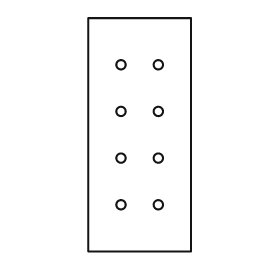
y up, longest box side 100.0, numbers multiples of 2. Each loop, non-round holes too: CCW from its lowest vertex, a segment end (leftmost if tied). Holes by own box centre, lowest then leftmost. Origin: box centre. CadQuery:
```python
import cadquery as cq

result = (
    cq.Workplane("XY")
    .moveTo(-22.0, -50.0)
    .lineTo(22.0, -50.0)
    .lineTo(22.0, 50.0)
    .lineTo(-22.0, 50.0)
    .close()
    .moveTo(-8.0, -30.0)
    .circle(2.0)
    .moveTo(8.0, -30.0)
    .circle(2.0)
    .moveTo(-8.0, -10.0)
    .circle(2.0)
    .moveTo(8.0, -10.0)
    .circle(2.0)
    .moveTo(-8.0, 10.0)
    .circle(2.0)
    .moveTo(8.0, 10.0)
    .circle(2.0)
    .moveTo(-8.0, 30.0)
    .circle(2.0)
    .moveTo(8.0, 30.0)
    .circle(2.0)
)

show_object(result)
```